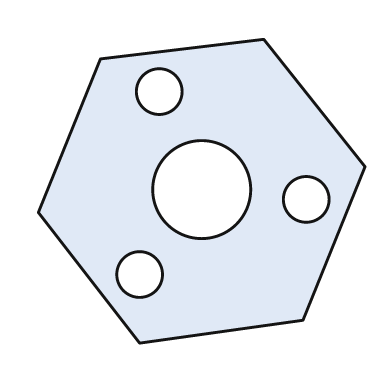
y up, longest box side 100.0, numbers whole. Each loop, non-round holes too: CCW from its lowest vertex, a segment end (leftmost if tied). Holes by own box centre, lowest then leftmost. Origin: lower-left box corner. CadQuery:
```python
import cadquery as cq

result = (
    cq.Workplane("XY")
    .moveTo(31.0, 0.0)
    .lineTo(81.0, 7.0)
    .lineTo(100.0, 54.0)
    .lineTo(69.0, 93.0)
    .lineTo(19.0, 87.0)
    .lineTo(0.0, 40.0)
    .close()
    .moveTo(31.0, 21.0)
    .circle(7.0)
    .moveTo(82.0, 44.0)
    .circle(7.0)
    .moveTo(50.0, 47.0)
    .circle(15.0)
    .moveTo(37.0, 77.0)
    .circle(7.0)
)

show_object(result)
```